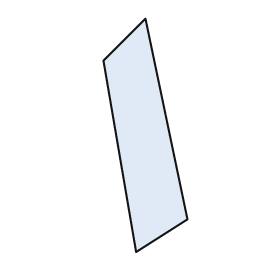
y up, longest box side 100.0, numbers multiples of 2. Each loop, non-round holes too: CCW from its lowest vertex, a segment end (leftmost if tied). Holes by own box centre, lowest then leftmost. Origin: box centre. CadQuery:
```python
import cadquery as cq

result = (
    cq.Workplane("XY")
    .moveTo(-4.0, -50.0)
    .lineTo(18.0, -36.0)
    .lineTo(0.0, 50.0)
    .lineTo(-18.0, 32.0)
    .close()
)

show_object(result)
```